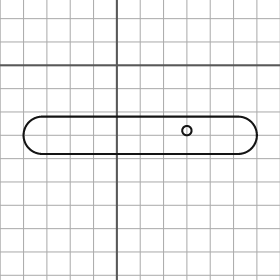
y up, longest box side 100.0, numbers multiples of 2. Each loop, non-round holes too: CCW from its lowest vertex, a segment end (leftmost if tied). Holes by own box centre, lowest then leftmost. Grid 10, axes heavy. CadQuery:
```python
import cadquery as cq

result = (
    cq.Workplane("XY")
    .moveTo(-32.0, -38.0)
    .lineTo(52.0, -38.0)
    .threePointArc((60.0, -30.0), (52.0, -22.0))
    .lineTo(-32.0, -22.0)
    .threePointArc((-40.0, -30.0), (-32.0, -38.0))
    .close()
    .moveTo(30.0, -28.0)
    .circle(2.0)
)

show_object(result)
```